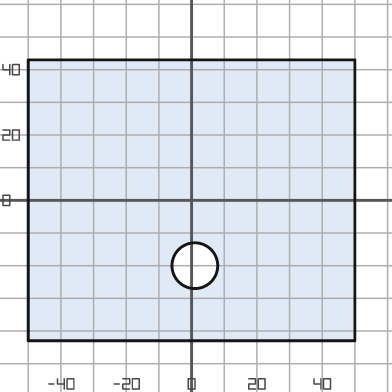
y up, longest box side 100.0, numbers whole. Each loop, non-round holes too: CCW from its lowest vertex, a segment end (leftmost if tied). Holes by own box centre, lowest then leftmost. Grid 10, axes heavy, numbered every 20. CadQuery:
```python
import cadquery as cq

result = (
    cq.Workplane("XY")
    .moveTo(-50.0, -43.0)
    .lineTo(50.0, -43.0)
    .lineTo(50.0, 43.0)
    .lineTo(-50.0, 43.0)
    .close()
    .moveTo(1.0, -20.0)
    .circle(7.0)
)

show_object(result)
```